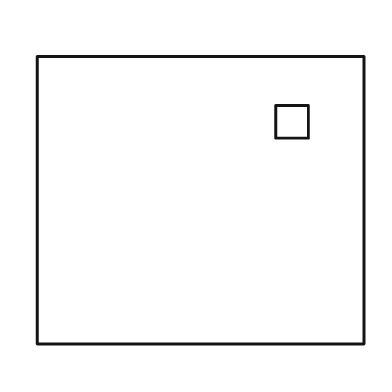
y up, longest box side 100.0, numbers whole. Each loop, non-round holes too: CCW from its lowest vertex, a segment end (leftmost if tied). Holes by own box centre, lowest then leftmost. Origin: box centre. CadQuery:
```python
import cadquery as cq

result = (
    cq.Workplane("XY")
    .moveTo(-50.0, -44.0)
    .lineTo(50.0, -44.0)
    .lineTo(50.0, 44.0)
    .lineTo(-50.0, 44.0)
    .close()
    .moveTo(23.0, 19.0)
    .lineTo(33.0, 19.0)
    .lineTo(33.0, 29.0)
    .lineTo(23.0, 29.0)
    .close()
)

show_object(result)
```